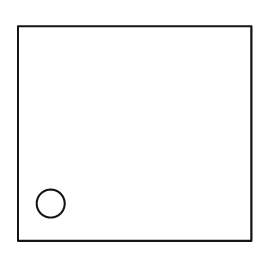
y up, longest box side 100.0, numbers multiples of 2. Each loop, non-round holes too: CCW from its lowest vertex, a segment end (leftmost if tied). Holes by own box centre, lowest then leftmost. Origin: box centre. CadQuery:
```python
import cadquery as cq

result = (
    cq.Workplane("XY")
    .moveTo(-50.0, -46.0)
    .lineTo(50.0, -46.0)
    .lineTo(50.0, 46.0)
    .lineTo(-50.0, 46.0)
    .close()
    .moveTo(-36.0, -30.0)
    .circle(6.0)
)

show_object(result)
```